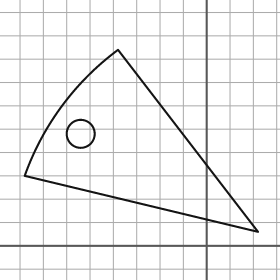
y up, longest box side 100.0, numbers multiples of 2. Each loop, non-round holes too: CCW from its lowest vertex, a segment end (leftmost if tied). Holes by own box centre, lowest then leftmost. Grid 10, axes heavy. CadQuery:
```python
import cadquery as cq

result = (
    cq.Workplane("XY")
    .moveTo(22.0, 6.0)
    .lineTo(-38.0, 84.0)
    .threePointArc((-62.0, 60.0), (-78.0, 30.0))
    .close()
    .moveTo(-54.0, 48.0)
    .circle(6.0)
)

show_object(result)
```